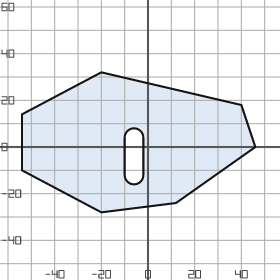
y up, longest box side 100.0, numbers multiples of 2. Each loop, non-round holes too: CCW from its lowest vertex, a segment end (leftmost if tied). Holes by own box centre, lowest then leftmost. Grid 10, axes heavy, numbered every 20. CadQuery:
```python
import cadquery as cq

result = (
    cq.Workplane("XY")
    .moveTo(-20.0, -28.0)
    .lineTo(12.0, -24.0)
    .lineTo(46.0, 0.0)
    .lineTo(40.0, 18.0)
    .lineTo(-20.0, 32.0)
    .lineTo(-54.0, 14.0)
    .lineTo(-54.0, -10.0)
    .close()
    .moveTo(-10.0, -12.0)
    .threePointArc((-6.0, -16.0), (-2.0, -12.0))
    .lineTo(-2.0, 4.0)
    .threePointArc((-6.0, 8.0), (-10.0, 4.0))
    .close()
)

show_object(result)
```